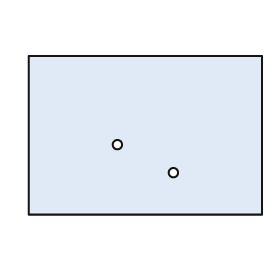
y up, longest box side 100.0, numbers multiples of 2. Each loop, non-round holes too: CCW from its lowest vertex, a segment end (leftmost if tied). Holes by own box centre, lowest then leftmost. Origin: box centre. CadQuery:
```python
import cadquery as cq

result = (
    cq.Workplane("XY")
    .moveTo(-50.0, -34.0)
    .lineTo(50.0, -34.0)
    .lineTo(50.0, 34.0)
    .lineTo(-50.0, 34.0)
    .close()
    .moveTo(12.0, -16.0)
    .circle(2.0)
    .moveTo(-12.0, -4.0)
    .circle(2.0)
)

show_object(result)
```